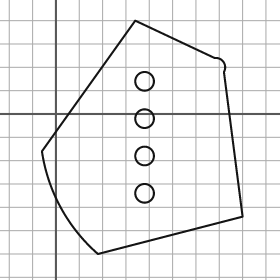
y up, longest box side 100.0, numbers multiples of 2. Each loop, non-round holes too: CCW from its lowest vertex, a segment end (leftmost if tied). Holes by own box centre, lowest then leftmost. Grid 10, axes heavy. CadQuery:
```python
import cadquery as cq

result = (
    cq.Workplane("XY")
    .moveTo(18.0, -60.0)
    .lineTo(80.0, -44.0)
    .lineTo(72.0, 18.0)
    .threePointArc((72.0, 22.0), (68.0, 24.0))
    .lineTo(34.0, 40.0)
    .lineTo(-6.0, -16.0)
    .threePointArc((2.0, -40.0), (18.0, -60.0))
    .close()
    .moveTo(38.0, -34.0)
    .circle(4.0)
    .moveTo(38.0, -18.0)
    .circle(4.0)
    .moveTo(38.0, -2.0)
    .circle(4.0)
    .moveTo(38.0, 14.0)
    .circle(4.0)
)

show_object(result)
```